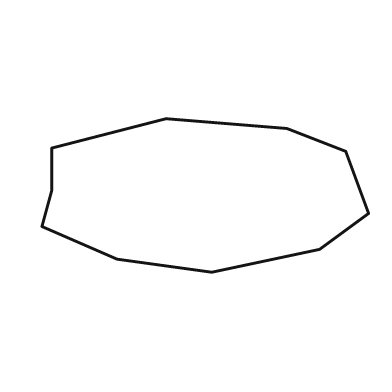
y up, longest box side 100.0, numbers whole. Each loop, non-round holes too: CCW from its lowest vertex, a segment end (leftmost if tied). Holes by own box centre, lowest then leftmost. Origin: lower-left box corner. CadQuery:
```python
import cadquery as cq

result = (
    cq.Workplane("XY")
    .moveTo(52.0, 0.0)
    .lineTo(85.0, 7.0)
    .lineTo(100.0, 18.0)
    .lineTo(93.0, 37.0)
    .lineTo(75.0, 44.0)
    .lineTo(38.0, 47.0)
    .lineTo(3.0, 38.0)
    .lineTo(3.0, 25.0)
    .lineTo(0.0, 14.0)
    .lineTo(23.0, 4.0)
    .close()
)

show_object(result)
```